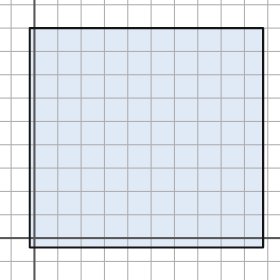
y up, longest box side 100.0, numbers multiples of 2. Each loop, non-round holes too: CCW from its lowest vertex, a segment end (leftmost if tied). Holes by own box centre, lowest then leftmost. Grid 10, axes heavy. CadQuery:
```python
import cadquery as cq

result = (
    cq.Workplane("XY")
    .moveTo(-2.0, -4.0)
    .lineTo(98.0, -4.0)
    .lineTo(98.0, 90.0)
    .lineTo(-2.0, 90.0)
    .close()
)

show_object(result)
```